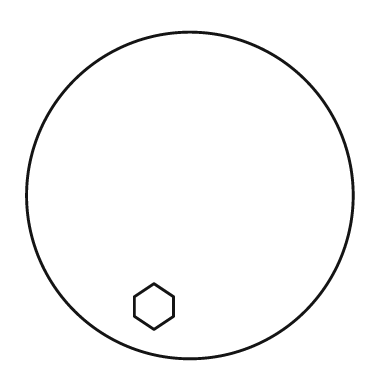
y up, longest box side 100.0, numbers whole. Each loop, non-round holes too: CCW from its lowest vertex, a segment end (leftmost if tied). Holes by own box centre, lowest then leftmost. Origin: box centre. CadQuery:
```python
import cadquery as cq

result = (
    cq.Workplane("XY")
    .moveTo(0.0, 0.0)
    .circle(50.0)
    .moveTo(-11.0, -41.0)
    .lineTo(-5.0, -37.0)
    .lineTo(-5.0, -31.0)
    .lineTo(-11.0, -27.0)
    .lineTo(-17.0, -31.0)
    .lineTo(-17.0, -37.0)
    .close()
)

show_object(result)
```